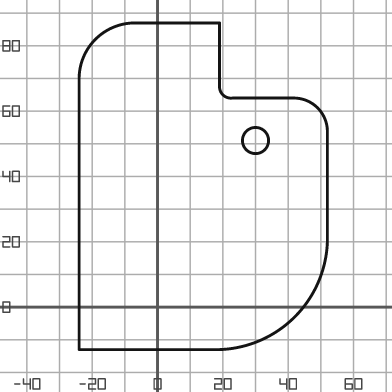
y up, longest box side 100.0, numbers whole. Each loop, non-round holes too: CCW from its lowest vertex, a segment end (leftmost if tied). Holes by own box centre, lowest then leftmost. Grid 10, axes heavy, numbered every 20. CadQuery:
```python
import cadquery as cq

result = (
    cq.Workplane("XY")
    .moveTo(-24.0, -13.0)
    .lineTo(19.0, -13.0)
    .threePointArc((42.0, -3.0), (52.0, 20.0))
    .lineTo(52.0, 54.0)
    .threePointArc((49.0, 61.0), (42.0, 64.0))
    .lineTo(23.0, 64.0)
    .threePointArc((20.0, 65.0), (19.0, 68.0))
    .lineTo(19.0, 87.0)
    .lineTo(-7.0, 87.0)
    .threePointArc((-19.0, 82.0), (-24.0, 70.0))
    .close()
    .moveTo(30.0, 51.0)
    .circle(4.0)
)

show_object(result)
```